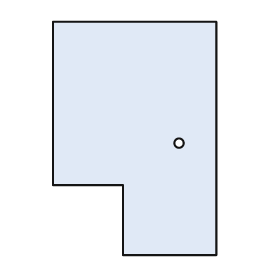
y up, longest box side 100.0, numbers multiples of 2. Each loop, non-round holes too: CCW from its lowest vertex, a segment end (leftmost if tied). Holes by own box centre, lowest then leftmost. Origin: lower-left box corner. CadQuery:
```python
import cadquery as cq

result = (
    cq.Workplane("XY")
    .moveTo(30.0, 0.0)
    .lineTo(70.0, 0.0)
    .lineTo(70.0, 100.0)
    .lineTo(0.0, 100.0)
    .lineTo(0.0, 30.0)
    .lineTo(30.0, 30.0)
    .close()
    .moveTo(54.0, 48.0)
    .circle(2.0)
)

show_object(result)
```